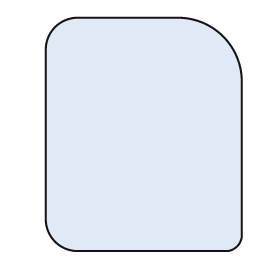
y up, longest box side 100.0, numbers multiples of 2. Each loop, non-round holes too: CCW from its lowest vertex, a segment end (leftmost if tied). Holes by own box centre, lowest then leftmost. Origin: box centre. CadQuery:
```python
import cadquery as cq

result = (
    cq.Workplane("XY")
    .moveTo(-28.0, -50.0)
    .lineTo(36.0, -50.0)
    .threePointArc((40.0, -48.0), (42.0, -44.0))
    .lineTo(42.0, 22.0)
    .threePointArc((34.0, 42.0), (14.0, 50.0))
    .lineTo(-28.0, 50.0)
    .threePointArc((-38.0, 46.0), (-42.0, 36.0))
    .lineTo(-42.0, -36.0)
    .threePointArc((-38.0, -46.0), (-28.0, -50.0))
    .close()
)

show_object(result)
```